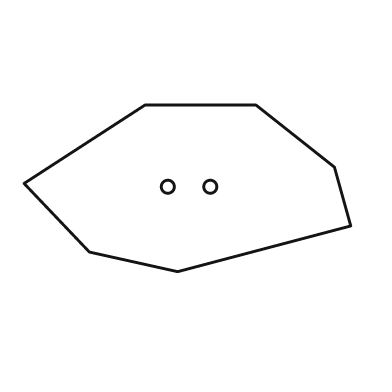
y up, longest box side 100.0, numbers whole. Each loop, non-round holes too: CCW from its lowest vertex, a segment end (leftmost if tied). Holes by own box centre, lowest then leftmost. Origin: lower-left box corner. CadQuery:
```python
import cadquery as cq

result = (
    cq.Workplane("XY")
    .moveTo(47.0, 0.0)
    .lineTo(100.0, 14.0)
    .lineTo(95.0, 32.0)
    .lineTo(71.0, 51.0)
    .lineTo(37.0, 51.0)
    .lineTo(0.0, 27.0)
    .lineTo(20.0, 6.0)
    .close()
    .moveTo(44.0, 26.0)
    .circle(2.0)
    .moveTo(57.0, 26.0)
    .circle(2.0)
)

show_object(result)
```